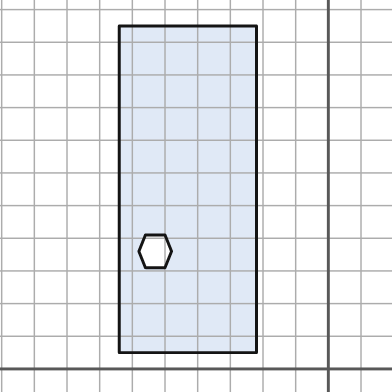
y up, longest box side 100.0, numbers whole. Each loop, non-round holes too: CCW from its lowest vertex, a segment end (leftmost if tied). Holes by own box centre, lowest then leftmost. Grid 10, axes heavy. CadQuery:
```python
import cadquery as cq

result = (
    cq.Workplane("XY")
    .moveTo(-64.0, 5.0)
    .lineTo(-22.0, 5.0)
    .lineTo(-22.0, 105.0)
    .lineTo(-64.0, 105.0)
    .close()
    .moveTo(-56.0, 31.0)
    .lineTo(-50.0, 31.0)
    .lineTo(-48.0, 36.0)
    .lineTo(-50.0, 41.0)
    .lineTo(-56.0, 41.0)
    .lineTo(-58.0, 36.0)
    .close()
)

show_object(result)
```